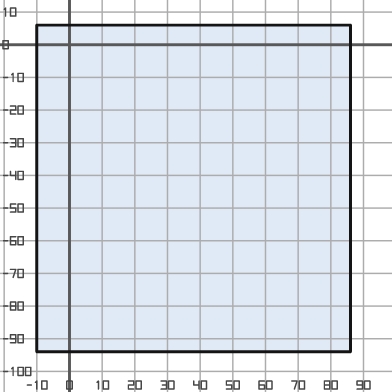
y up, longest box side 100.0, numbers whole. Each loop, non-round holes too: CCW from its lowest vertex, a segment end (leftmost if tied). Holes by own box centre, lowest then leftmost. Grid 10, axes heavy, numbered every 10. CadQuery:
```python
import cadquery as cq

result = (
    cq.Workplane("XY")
    .moveTo(-10.0, -94.0)
    .lineTo(86.0, -94.0)
    .lineTo(86.0, 6.0)
    .lineTo(-10.0, 6.0)
    .close()
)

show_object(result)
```